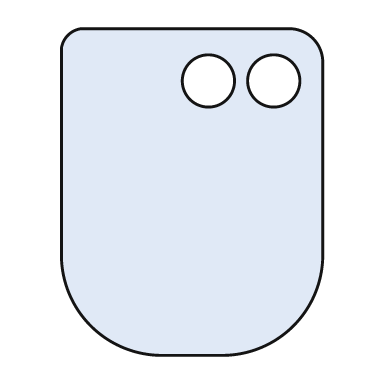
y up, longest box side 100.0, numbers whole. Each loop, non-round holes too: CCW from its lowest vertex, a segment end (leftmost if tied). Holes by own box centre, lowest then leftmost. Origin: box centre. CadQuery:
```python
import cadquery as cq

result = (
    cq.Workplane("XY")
    .moveTo(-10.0, -50.0)
    .lineTo(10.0, -50.0)
    .threePointArc((31.0, -41.0), (40.0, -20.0))
    .lineTo(40.0, 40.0)
    .threePointArc((37.0, 47.0), (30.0, 50.0))
    .lineTo(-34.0, 50.0)
    .threePointArc((-38.0, 48.0), (-40.0, 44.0))
    .lineTo(-40.0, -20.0)
    .threePointArc((-31.0, -41.0), (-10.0, -50.0))
    .close()
    .moveTo(5.0, 34.0)
    .circle(8.0)
    .moveTo(25.0, 34.0)
    .circle(8.0)
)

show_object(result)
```